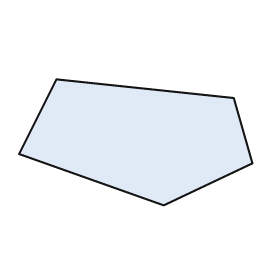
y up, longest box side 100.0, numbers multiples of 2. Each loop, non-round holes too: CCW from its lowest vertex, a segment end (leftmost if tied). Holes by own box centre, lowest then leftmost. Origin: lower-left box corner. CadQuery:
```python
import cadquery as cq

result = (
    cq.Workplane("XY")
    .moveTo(62.0, 0.0)
    .lineTo(100.0, 18.0)
    .lineTo(92.0, 46.0)
    .lineTo(16.0, 54.0)
    .lineTo(0.0, 22.0)
    .close()
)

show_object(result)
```